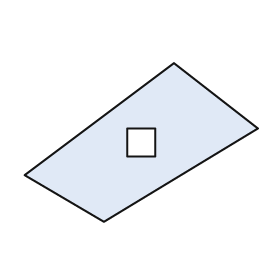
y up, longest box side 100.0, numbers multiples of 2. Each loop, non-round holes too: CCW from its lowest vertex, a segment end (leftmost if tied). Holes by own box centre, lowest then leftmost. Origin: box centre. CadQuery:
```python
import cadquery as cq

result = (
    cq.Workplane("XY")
    .moveTo(-16.0, -34.0)
    .lineTo(50.0, 6.0)
    .lineTo(14.0, 34.0)
    .lineTo(-50.0, -14.0)
    .close()
    .moveTo(-6.0, -6.0)
    .lineTo(6.0, -6.0)
    .lineTo(6.0, 6.0)
    .lineTo(-6.0, 6.0)
    .close()
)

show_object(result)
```